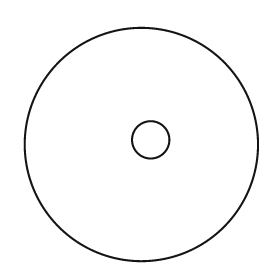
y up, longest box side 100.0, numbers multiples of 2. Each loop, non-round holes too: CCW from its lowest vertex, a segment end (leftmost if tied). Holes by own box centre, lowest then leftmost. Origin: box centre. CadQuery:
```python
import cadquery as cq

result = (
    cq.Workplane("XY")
    .moveTo(0.0, 0.0)
    .circle(50.0)
    .moveTo(4.0, 2.0)
    .circle(8.0)
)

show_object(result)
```